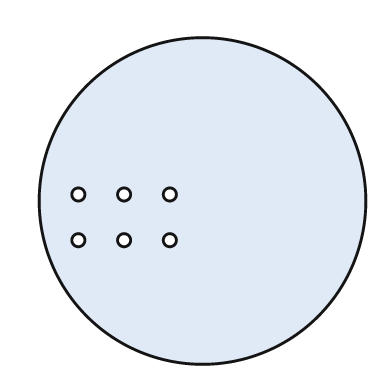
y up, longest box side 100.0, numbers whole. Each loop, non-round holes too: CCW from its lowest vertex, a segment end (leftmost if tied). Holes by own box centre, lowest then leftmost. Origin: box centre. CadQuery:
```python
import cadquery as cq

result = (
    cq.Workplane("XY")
    .moveTo(0.0, 0.0)
    .circle(50.0)
    .moveTo(-38.0, -12.0)
    .circle(2.0)
    .moveTo(-24.0, -12.0)
    .circle(2.0)
    .moveTo(-10.0, -12.0)
    .circle(2.0)
    .moveTo(-38.0, 2.0)
    .circle(2.0)
    .moveTo(-24.0, 2.0)
    .circle(2.0)
    .moveTo(-10.0, 2.0)
    .circle(2.0)
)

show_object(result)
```